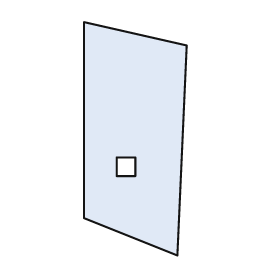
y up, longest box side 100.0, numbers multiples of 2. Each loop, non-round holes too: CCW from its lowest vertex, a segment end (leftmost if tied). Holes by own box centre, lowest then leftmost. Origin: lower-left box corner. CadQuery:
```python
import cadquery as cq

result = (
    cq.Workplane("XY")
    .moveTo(40.0, 0.0)
    .lineTo(44.0, 90.0)
    .lineTo(0.0, 100.0)
    .lineTo(0.0, 16.0)
    .close()
    .moveTo(14.0, 34.0)
    .lineTo(22.0, 34.0)
    .lineTo(22.0, 42.0)
    .lineTo(14.0, 42.0)
    .close()
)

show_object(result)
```